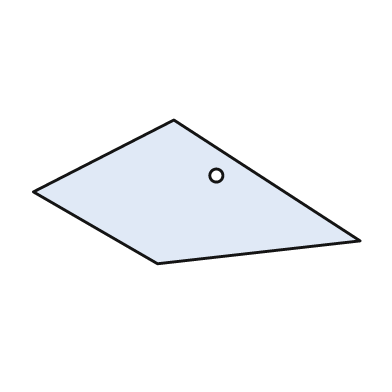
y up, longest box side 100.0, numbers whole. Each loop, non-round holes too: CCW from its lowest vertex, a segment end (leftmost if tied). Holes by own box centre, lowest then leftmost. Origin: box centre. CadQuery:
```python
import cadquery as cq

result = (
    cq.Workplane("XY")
    .moveTo(-12.0, -22.0)
    .lineTo(50.0, -15.0)
    .lineTo(-7.0, 22.0)
    .lineTo(-50.0, 0.0)
    .close()
    .moveTo(6.0, 5.0)
    .circle(2.0)
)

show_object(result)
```